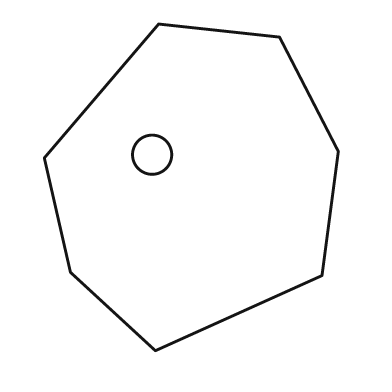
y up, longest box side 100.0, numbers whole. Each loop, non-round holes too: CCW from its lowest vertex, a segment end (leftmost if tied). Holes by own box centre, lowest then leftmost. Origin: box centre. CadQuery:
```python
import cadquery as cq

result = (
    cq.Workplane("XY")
    .moveTo(-11.0, -50.0)
    .lineTo(40.0, -27.0)
    .lineTo(45.0, 11.0)
    .lineTo(27.0, 46.0)
    .lineTo(-10.0, 50.0)
    .lineTo(-45.0, 9.0)
    .lineTo(-37.0, -26.0)
    .close()
    .moveTo(-12.0, 10.0)
    .circle(6.0)
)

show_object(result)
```